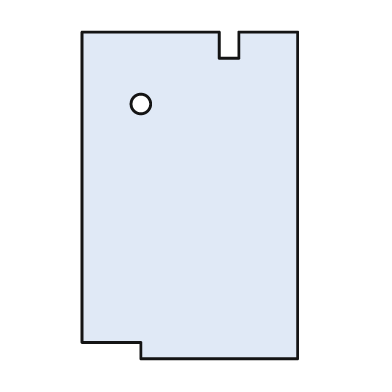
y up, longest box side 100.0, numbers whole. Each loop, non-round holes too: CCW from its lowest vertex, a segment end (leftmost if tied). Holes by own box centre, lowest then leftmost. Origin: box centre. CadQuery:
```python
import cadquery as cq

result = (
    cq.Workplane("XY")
    .moveTo(-15.0, -50.0)
    .lineTo(33.0, -50.0)
    .lineTo(33.0, 50.0)
    .lineTo(15.0, 50.0)
    .lineTo(15.0, 42.0)
    .lineTo(9.0, 42.0)
    .lineTo(9.0, 50.0)
    .lineTo(-33.0, 50.0)
    .lineTo(-33.0, -45.0)
    .lineTo(-15.0, -45.0)
    .close()
    .moveTo(-15.0, 28.0)
    .circle(3.0)
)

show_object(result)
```